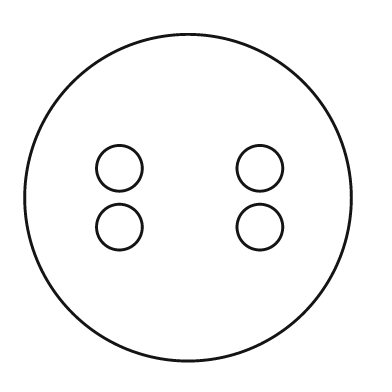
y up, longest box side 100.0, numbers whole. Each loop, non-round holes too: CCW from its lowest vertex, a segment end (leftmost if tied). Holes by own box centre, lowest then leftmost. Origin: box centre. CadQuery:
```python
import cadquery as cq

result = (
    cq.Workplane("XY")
    .moveTo(0.0, 0.0)
    .circle(50.0)
    .moveTo(-21.0, -9.0)
    .circle(7.0)
    .moveTo(22.0, -9.0)
    .circle(7.0)
    .moveTo(-21.0, 9.0)
    .circle(7.0)
    .moveTo(22.0, 9.0)
    .circle(7.0)
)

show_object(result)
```